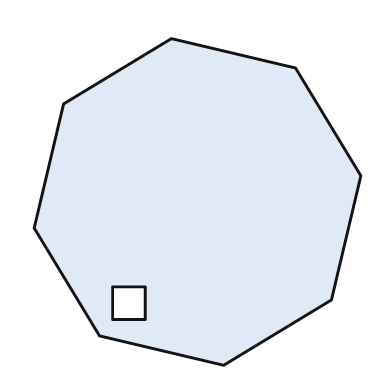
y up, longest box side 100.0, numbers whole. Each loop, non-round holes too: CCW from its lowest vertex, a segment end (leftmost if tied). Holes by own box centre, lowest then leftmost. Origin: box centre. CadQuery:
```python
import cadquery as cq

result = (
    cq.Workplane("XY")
    .moveTo(8.0, -50.0)
    .lineTo(41.0, -30.0)
    .lineTo(50.0, 8.0)
    .lineTo(30.0, 41.0)
    .lineTo(-8.0, 50.0)
    .lineTo(-41.0, 30.0)
    .lineTo(-50.0, -8.0)
    .lineTo(-30.0, -41.0)
    .close()
    .moveTo(-26.0, -36.0)
    .lineTo(-16.0, -36.0)
    .lineTo(-16.0, -26.0)
    .lineTo(-26.0, -26.0)
    .close()
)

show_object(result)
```